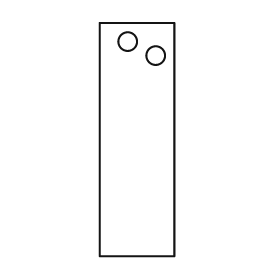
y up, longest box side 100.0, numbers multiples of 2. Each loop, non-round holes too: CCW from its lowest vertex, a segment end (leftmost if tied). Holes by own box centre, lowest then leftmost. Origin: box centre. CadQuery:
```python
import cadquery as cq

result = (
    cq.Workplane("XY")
    .moveTo(-16.0, -50.0)
    .lineTo(16.0, -50.0)
    .lineTo(16.0, 50.0)
    .lineTo(-16.0, 50.0)
    .close()
    .moveTo(8.0, 36.0)
    .circle(4.0)
    .moveTo(-4.0, 42.0)
    .circle(4.0)
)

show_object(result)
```